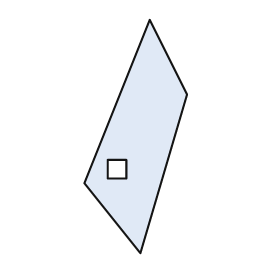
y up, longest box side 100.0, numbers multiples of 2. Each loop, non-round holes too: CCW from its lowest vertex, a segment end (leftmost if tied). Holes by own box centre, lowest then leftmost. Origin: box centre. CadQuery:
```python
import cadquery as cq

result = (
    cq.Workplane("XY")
    .moveTo(2.0, -50.0)
    .lineTo(22.0, 18.0)
    .lineTo(6.0, 50.0)
    .lineTo(-22.0, -20.0)
    .close()
    .moveTo(-12.0, -18.0)
    .lineTo(-4.0, -18.0)
    .lineTo(-4.0, -10.0)
    .lineTo(-12.0, -10.0)
    .close()
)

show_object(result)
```